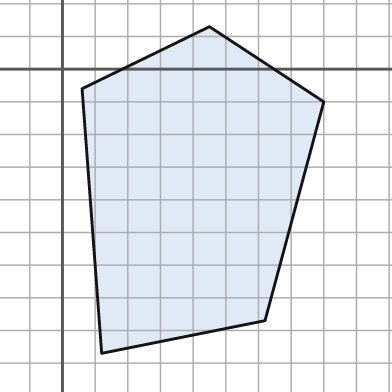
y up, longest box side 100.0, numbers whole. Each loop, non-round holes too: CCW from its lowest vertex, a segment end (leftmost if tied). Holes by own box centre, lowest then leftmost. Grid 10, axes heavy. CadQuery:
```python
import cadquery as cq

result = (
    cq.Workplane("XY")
    .moveTo(12.0, -87.0)
    .lineTo(62.0, -77.0)
    .lineTo(80.0, -10.0)
    .lineTo(45.0, 13.0)
    .lineTo(6.0, -6.0)
    .close()
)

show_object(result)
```